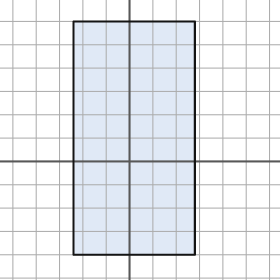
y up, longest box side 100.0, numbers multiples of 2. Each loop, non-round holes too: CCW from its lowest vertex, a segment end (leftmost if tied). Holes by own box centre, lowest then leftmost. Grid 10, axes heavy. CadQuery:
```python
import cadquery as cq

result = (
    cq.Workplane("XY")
    .moveTo(-24.0, -40.0)
    .lineTo(28.0, -40.0)
    .lineTo(28.0, 60.0)
    .lineTo(-24.0, 60.0)
    .close()
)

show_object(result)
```